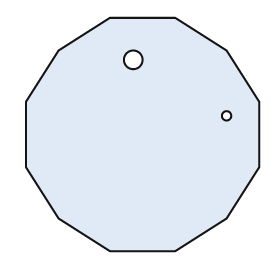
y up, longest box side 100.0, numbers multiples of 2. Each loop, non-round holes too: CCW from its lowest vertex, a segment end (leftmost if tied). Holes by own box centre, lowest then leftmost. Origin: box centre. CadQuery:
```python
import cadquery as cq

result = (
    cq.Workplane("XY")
    .moveTo(-14.0, -50.0)
    .lineTo(14.0, -50.0)
    .lineTo(36.0, -36.0)
    .lineTo(50.0, -14.0)
    .lineTo(50.0, 14.0)
    .lineTo(36.0, 36.0)
    .lineTo(14.0, 50.0)
    .lineTo(-14.0, 50.0)
    .lineTo(-36.0, 36.0)
    .lineTo(-50.0, 14.0)
    .lineTo(-50.0, -14.0)
    .lineTo(-36.0, -36.0)
    .close()
    .moveTo(36.0, 8.0)
    .circle(2.0)
    .moveTo(-4.0, 32.0)
    .circle(4.0)
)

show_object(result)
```